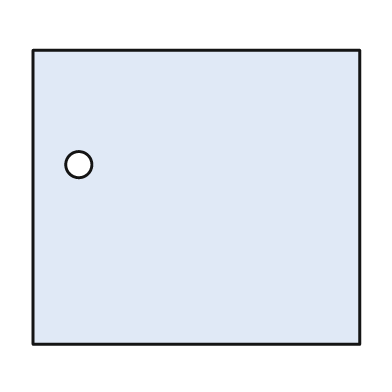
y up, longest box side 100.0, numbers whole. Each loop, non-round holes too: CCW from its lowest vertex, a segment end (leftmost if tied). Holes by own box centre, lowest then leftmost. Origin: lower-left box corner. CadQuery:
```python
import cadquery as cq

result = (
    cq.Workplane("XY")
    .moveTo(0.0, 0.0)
    .lineTo(100.0, 0.0)
    .lineTo(100.0, 90.0)
    .lineTo(0.0, 90.0)
    .close()
    .moveTo(14.0, 55.0)
    .circle(4.0)
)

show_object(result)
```